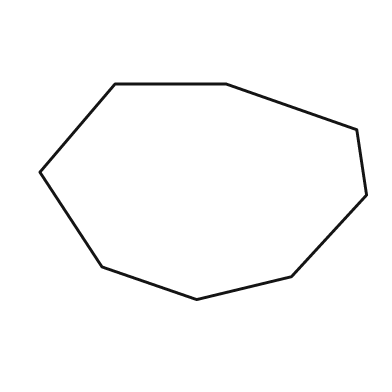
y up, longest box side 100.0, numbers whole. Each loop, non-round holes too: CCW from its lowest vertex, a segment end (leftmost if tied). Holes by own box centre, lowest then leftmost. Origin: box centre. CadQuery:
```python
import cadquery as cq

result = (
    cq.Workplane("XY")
    .moveTo(-2.0, -33.0)
    .lineTo(27.0, -26.0)
    .lineTo(50.0, -1.0)
    .lineTo(47.0, 19.0)
    .lineTo(7.0, 33.0)
    .lineTo(-27.0, 33.0)
    .lineTo(-50.0, 6.0)
    .lineTo(-31.0, -23.0)
    .close()
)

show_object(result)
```